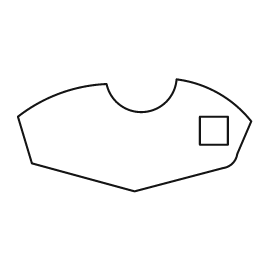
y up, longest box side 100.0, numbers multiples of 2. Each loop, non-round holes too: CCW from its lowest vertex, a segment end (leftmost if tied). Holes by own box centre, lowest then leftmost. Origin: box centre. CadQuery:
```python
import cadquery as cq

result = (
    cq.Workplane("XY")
    .moveTo(0.0, -24.0)
    .lineTo(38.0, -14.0)
    .threePointArc((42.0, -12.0), (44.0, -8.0))
    .lineTo(50.0, 6.0)
    .threePointArc((36.0, 18.0), (18.0, 24.0))
    .threePointArc((4.0, 10.0), (-12.0, 22.0))
    .threePointArc((-32.0, 18.0), (-50.0, 8.0))
    .lineTo(-44.0, -12.0)
    .close()
    .moveTo(28.0, -4.0)
    .lineTo(40.0, -4.0)
    .lineTo(40.0, 8.0)
    .lineTo(28.0, 8.0)
    .close()
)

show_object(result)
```